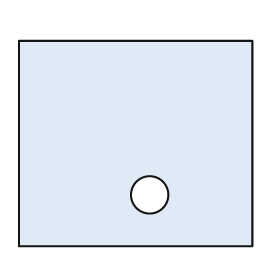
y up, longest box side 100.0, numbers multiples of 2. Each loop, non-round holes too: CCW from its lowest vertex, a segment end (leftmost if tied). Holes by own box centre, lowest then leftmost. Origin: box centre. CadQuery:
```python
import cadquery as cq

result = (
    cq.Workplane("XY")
    .moveTo(-50.0, -44.0)
    .lineTo(50.0, -44.0)
    .lineTo(50.0, 44.0)
    .lineTo(-50.0, 44.0)
    .close()
    .moveTo(6.0, -22.0)
    .circle(8.0)
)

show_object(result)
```